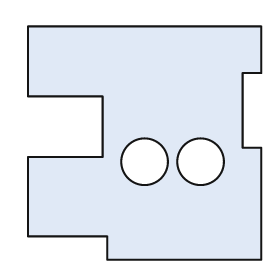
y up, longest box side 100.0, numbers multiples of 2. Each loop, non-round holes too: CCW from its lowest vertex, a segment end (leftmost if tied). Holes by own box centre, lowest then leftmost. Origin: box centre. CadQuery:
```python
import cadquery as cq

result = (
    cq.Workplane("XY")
    .moveTo(-16.0, -50.0)
    .lineTo(50.0, -50.0)
    .lineTo(50.0, -2.0)
    .lineTo(42.0, -2.0)
    .lineTo(42.0, 30.0)
    .lineTo(50.0, 30.0)
    .lineTo(50.0, 50.0)
    .lineTo(-50.0, 50.0)
    .lineTo(-50.0, 20.0)
    .lineTo(-18.0, 20.0)
    .lineTo(-18.0, -6.0)
    .lineTo(-50.0, -6.0)
    .lineTo(-50.0, -40.0)
    .lineTo(-16.0, -40.0)
    .close()
    .moveTo(0.0, -8.0)
    .circle(10.0)
    .moveTo(24.0, -8.0)
    .circle(10.0)
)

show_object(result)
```